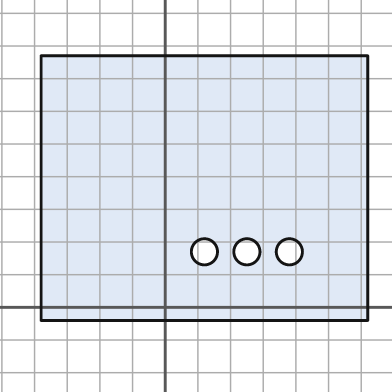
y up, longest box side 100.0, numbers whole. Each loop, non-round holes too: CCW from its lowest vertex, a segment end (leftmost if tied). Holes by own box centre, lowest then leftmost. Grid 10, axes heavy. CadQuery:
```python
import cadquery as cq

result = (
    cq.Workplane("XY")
    .moveTo(-38.0, -4.0)
    .lineTo(62.0, -4.0)
    .lineTo(62.0, 77.0)
    .lineTo(-38.0, 77.0)
    .close()
    .moveTo(12.0, 17.0)
    .circle(4.0)
    .moveTo(25.0, 17.0)
    .circle(4.0)
    .moveTo(38.0, 17.0)
    .circle(4.0)
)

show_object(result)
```